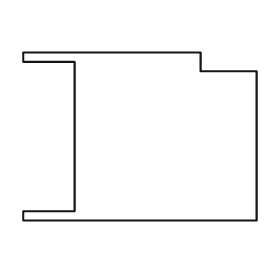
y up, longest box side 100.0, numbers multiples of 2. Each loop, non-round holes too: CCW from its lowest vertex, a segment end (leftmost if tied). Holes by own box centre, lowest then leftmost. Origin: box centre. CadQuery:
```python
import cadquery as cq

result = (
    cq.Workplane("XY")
    .moveTo(-50.0, -36.0)
    .lineTo(50.0, -36.0)
    .lineTo(50.0, 28.0)
    .lineTo(26.0, 28.0)
    .lineTo(26.0, 36.0)
    .lineTo(-50.0, 36.0)
    .lineTo(-50.0, 32.0)
    .lineTo(-28.0, 32.0)
    .lineTo(-28.0, -32.0)
    .lineTo(-50.0, -32.0)
    .close()
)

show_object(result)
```